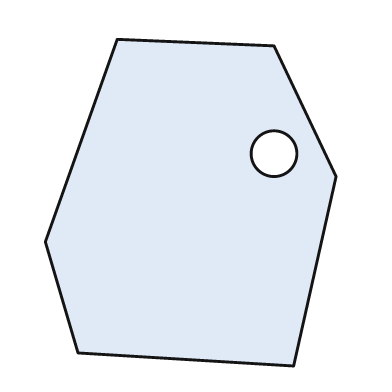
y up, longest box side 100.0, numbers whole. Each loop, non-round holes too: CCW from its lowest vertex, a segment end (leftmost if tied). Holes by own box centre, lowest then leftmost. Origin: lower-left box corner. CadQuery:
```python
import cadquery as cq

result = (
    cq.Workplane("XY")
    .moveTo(76.0, 0.0)
    .lineTo(89.0, 58.0)
    .lineTo(70.0, 98.0)
    .lineTo(22.0, 100.0)
    .lineTo(0.0, 38.0)
    .lineTo(10.0, 4.0)
    .close()
    .moveTo(70.0, 65.0)
    .circle(7.0)
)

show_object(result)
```